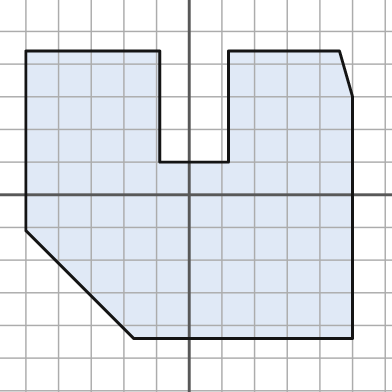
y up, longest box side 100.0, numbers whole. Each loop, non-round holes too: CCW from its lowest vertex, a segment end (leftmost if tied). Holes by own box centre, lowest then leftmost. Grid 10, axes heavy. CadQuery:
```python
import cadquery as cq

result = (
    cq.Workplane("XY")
    .moveTo(-17.0, -44.0)
    .lineTo(50.0, -44.0)
    .lineTo(50.0, 30.0)
    .lineTo(46.0, 44.0)
    .lineTo(12.0, 44.0)
    .lineTo(12.0, 10.0)
    .lineTo(-9.0, 10.0)
    .lineTo(-9.0, 44.0)
    .lineTo(-50.0, 44.0)
    .lineTo(-50.0, -11.0)
    .close()
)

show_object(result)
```